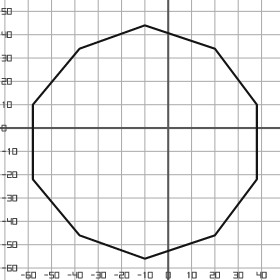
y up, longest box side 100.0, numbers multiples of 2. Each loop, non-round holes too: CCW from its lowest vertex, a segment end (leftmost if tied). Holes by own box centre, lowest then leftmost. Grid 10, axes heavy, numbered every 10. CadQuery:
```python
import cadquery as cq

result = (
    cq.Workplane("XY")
    .moveTo(-10.0, -56.0)
    .lineTo(20.0, -46.0)
    .lineTo(38.0, -22.0)
    .lineTo(38.0, 10.0)
    .lineTo(20.0, 34.0)
    .lineTo(-10.0, 44.0)
    .lineTo(-38.0, 34.0)
    .lineTo(-58.0, 10.0)
    .lineTo(-58.0, -22.0)
    .lineTo(-38.0, -46.0)
    .close()
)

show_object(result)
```